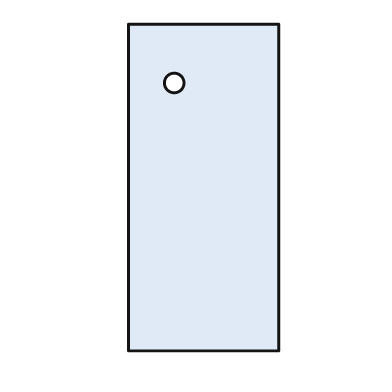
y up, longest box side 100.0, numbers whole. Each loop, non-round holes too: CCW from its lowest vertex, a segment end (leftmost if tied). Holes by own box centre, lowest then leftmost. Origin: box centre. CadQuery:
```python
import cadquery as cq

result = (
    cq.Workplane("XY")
    .moveTo(-23.0, -50.0)
    .lineTo(23.0, -50.0)
    .lineTo(23.0, 50.0)
    .lineTo(-23.0, 50.0)
    .close()
    .moveTo(-9.0, 32.0)
    .circle(3.0)
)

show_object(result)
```